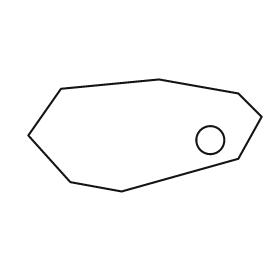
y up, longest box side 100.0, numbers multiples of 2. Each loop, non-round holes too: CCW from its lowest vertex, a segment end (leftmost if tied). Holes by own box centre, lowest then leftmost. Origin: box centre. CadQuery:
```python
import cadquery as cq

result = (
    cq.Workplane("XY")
    .moveTo(-10.0, -24.0)
    .lineTo(40.0, -10.0)
    .lineTo(50.0, 8.0)
    .lineTo(40.0, 18.0)
    .lineTo(6.0, 24.0)
    .lineTo(-36.0, 20.0)
    .lineTo(-50.0, 0.0)
    .lineTo(-32.0, -20.0)
    .close()
    .moveTo(28.0, -2.0)
    .circle(6.0)
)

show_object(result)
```